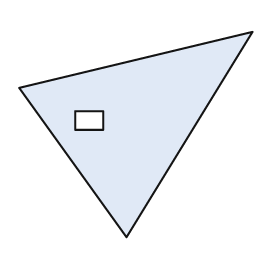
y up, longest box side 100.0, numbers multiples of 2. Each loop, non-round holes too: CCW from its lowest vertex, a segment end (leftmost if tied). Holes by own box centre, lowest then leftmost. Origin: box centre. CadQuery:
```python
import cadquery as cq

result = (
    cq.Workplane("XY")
    .moveTo(-4.0, -44.0)
    .lineTo(50.0, 44.0)
    .lineTo(-50.0, 20.0)
    .close()
    .moveTo(-26.0, 2.0)
    .lineTo(-14.0, 2.0)
    .lineTo(-14.0, 10.0)
    .lineTo(-26.0, 10.0)
    .close()
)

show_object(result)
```